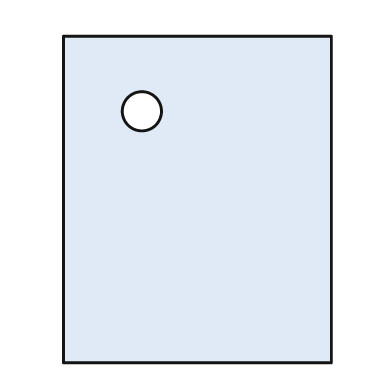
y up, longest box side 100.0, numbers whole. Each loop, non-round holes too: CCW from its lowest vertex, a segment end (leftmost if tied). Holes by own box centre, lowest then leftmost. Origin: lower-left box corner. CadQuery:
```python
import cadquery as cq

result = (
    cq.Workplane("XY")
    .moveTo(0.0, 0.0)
    .lineTo(82.0, 0.0)
    .lineTo(82.0, 100.0)
    .lineTo(0.0, 100.0)
    .close()
    .moveTo(24.0, 77.0)
    .circle(6.0)
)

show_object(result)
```